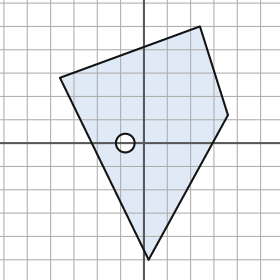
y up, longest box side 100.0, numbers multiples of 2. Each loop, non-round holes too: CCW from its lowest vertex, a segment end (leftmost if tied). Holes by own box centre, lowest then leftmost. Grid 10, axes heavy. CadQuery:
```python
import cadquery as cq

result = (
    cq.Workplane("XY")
    .moveTo(2.0, -50.0)
    .lineTo(36.0, 12.0)
    .lineTo(24.0, 50.0)
    .lineTo(-36.0, 28.0)
    .close()
    .moveTo(-8.0, 0.0)
    .circle(4.0)
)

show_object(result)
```